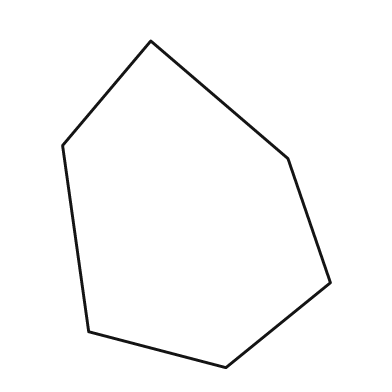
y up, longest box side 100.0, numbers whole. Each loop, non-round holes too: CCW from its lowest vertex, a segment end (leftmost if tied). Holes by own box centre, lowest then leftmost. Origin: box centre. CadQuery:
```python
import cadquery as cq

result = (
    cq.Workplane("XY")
    .moveTo(9.0, -50.0)
    .lineTo(41.0, -24.0)
    .lineTo(28.0, 14.0)
    .lineTo(-14.0, 50.0)
    .lineTo(-41.0, 18.0)
    .lineTo(-33.0, -39.0)
    .close()
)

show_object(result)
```